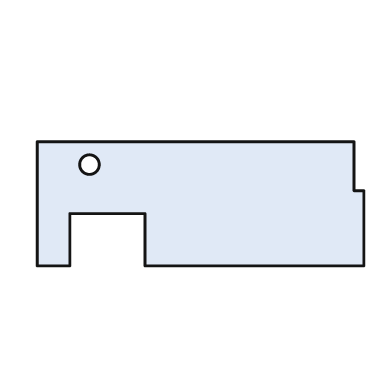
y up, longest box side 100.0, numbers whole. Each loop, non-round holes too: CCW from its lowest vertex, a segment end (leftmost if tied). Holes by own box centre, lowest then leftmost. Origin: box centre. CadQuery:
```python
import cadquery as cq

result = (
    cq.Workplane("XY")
    .moveTo(-50.0, -19.0)
    .lineTo(-40.0, -19.0)
    .lineTo(-40.0, -3.0)
    .lineTo(-17.0, -3.0)
    .lineTo(-17.0, -19.0)
    .lineTo(50.0, -19.0)
    .lineTo(50.0, 4.0)
    .lineTo(47.0, 4.0)
    .lineTo(47.0, 19.0)
    .lineTo(-50.0, 19.0)
    .close()
    .moveTo(-34.0, 12.0)
    .circle(3.0)
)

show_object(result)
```